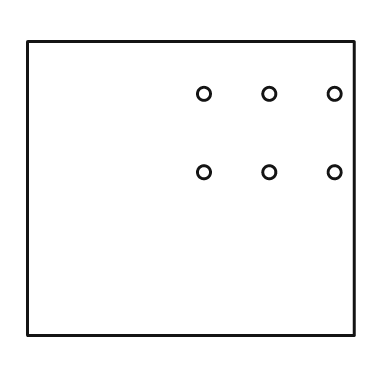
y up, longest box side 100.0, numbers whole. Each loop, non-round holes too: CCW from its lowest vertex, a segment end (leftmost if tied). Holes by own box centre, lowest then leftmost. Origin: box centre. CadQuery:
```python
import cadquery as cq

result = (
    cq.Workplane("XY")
    .moveTo(-50.0, -45.0)
    .lineTo(50.0, -45.0)
    .lineTo(50.0, 45.0)
    .lineTo(-50.0, 45.0)
    .close()
    .moveTo(4.0, 5.0)
    .circle(2.0)
    .moveTo(24.0, 5.0)
    .circle(2.0)
    .moveTo(44.0, 5.0)
    .circle(2.0)
    .moveTo(4.0, 29.0)
    .circle(2.0)
    .moveTo(24.0, 29.0)
    .circle(2.0)
    .moveTo(44.0, 29.0)
    .circle(2.0)
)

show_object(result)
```